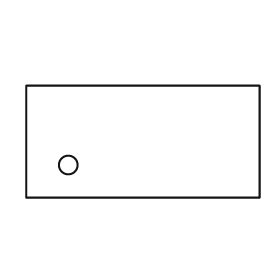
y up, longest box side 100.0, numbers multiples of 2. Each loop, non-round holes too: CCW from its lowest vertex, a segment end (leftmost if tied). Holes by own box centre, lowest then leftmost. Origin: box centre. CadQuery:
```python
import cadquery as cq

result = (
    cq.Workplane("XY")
    .moveTo(-50.0, -24.0)
    .lineTo(50.0, -24.0)
    .lineTo(50.0, 24.0)
    .lineTo(-50.0, 24.0)
    .close()
    .moveTo(-32.0, -10.0)
    .circle(4.0)
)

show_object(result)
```